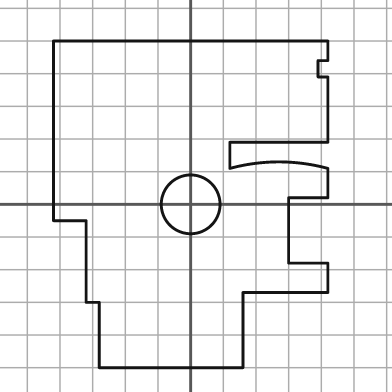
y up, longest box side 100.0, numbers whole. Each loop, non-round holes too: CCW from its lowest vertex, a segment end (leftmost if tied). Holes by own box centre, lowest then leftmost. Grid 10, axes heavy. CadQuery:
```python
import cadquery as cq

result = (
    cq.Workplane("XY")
    .moveTo(-28.0, -50.0)
    .lineTo(16.0, -50.0)
    .lineTo(16.0, -27.0)
    .lineTo(42.0, -27.0)
    .lineTo(42.0, -18.0)
    .lineTo(30.0, -18.0)
    .lineTo(30.0, 2.0)
    .lineTo(42.0, 2.0)
    .lineTo(42.0, 11.0)
    .threePointArc((27.0, 13.0), (12.0, 11.0))
    .lineTo(12.0, 19.0)
    .lineTo(42.0, 19.0)
    .lineTo(42.0, 39.0)
    .lineTo(39.0, 39.0)
    .lineTo(39.0, 44.0)
    .lineTo(42.0, 44.0)
    .lineTo(42.0, 50.0)
    .lineTo(-42.0, 50.0)
    .lineTo(-42.0, -5.0)
    .lineTo(-32.0, -5.0)
    .lineTo(-32.0, -30.0)
    .lineTo(-28.0, -30.0)
    .close()
    .moveTo(0.0, 0.0)
    .circle(9.0)
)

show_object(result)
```